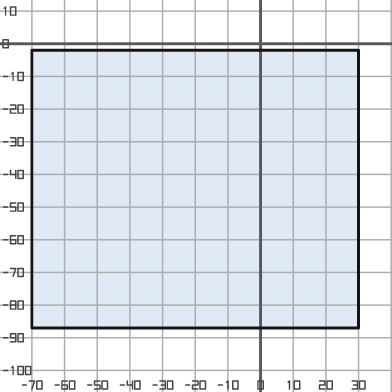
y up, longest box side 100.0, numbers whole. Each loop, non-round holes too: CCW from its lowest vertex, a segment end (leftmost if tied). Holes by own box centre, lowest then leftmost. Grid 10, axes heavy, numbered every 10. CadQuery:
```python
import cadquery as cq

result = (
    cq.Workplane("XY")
    .moveTo(-70.0, -87.0)
    .lineTo(30.0, -87.0)
    .lineTo(30.0, -2.0)
    .lineTo(-70.0, -2.0)
    .close()
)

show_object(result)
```